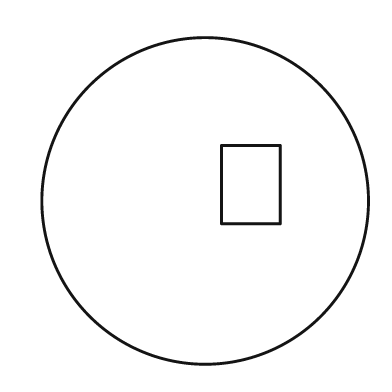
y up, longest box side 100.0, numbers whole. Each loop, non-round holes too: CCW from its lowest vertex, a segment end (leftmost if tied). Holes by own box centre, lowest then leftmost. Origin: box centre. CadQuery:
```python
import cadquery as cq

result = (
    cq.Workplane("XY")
    .moveTo(0.0, 0.0)
    .circle(50.0)
    .moveTo(5.0, -7.0)
    .lineTo(23.0, -7.0)
    .lineTo(23.0, 17.0)
    .lineTo(5.0, 17.0)
    .close()
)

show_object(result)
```